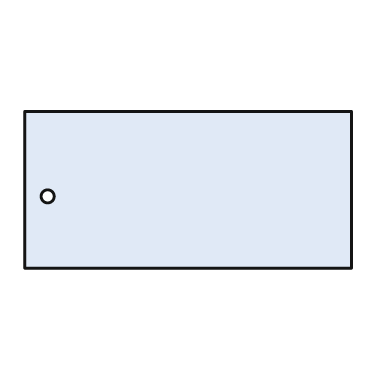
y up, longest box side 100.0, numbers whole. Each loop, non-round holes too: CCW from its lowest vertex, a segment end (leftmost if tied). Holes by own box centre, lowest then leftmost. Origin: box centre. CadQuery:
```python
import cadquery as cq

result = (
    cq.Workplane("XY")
    .moveTo(-50.0, -24.0)
    .lineTo(50.0, -24.0)
    .lineTo(50.0, 24.0)
    .lineTo(-50.0, 24.0)
    .close()
    .moveTo(-43.0, -2.0)
    .circle(2.0)
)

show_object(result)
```